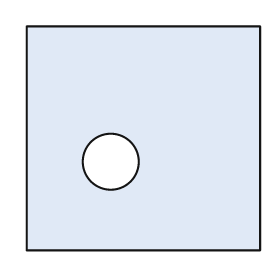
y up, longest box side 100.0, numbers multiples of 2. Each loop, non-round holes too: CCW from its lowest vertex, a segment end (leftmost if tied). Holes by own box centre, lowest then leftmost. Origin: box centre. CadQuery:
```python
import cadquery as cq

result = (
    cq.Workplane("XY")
    .moveTo(-50.0, -48.0)
    .lineTo(50.0, -48.0)
    .lineTo(50.0, 48.0)
    .lineTo(-50.0, 48.0)
    .close()
    .moveTo(-14.0, -10.0)
    .circle(12.0)
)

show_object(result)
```